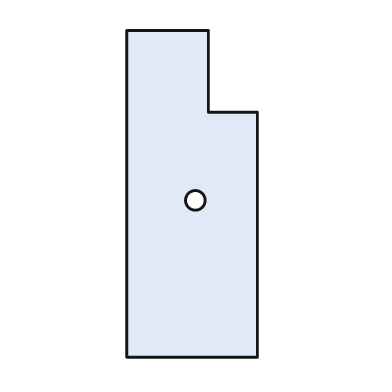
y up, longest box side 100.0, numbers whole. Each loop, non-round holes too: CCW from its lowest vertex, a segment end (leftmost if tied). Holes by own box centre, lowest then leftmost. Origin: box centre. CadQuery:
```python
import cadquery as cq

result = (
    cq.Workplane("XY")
    .moveTo(-20.0, -50.0)
    .lineTo(20.0, -50.0)
    .lineTo(20.0, 25.0)
    .lineTo(5.0, 25.0)
    .lineTo(5.0, 50.0)
    .lineTo(-20.0, 50.0)
    .close()
    .moveTo(1.0, -2.0)
    .circle(3.0)
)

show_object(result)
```